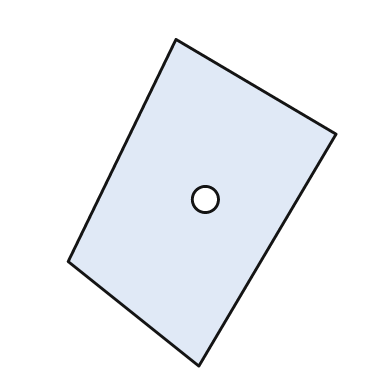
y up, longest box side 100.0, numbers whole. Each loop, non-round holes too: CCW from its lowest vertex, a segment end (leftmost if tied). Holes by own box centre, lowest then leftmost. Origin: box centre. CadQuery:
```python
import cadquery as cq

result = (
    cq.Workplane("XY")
    .moveTo(-1.0, -50.0)
    .lineTo(41.0, 21.0)
    .lineTo(-8.0, 50.0)
    .lineTo(-41.0, -18.0)
    .close()
    .moveTo(1.0, 1.0)
    .circle(4.0)
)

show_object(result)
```